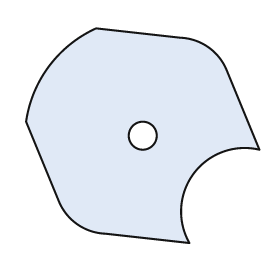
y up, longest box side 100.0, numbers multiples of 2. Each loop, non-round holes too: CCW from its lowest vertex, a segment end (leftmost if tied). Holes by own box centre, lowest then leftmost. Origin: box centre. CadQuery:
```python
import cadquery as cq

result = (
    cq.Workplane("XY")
    .moveTo(20.0, -46.0)
    .threePointArc((22.0, -16.0), (50.0, -6.0))
    .lineTo(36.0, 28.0)
    .threePointArc((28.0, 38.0), (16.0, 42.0))
    .lineTo(-20.0, 46.0)
    .threePointArc((-40.0, 30.0), (-50.0, 6.0))
    .lineTo(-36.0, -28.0)
    .threePointArc((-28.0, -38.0), (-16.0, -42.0))
    .close()
    .moveTo(0.0, 0.0)
    .circle(6.0)
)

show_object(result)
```